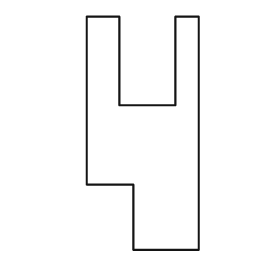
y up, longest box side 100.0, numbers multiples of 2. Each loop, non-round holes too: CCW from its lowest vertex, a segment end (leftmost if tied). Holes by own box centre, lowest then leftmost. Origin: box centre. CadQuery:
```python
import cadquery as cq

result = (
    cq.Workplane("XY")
    .moveTo(-4.0, -50.0)
    .lineTo(24.0, -50.0)
    .lineTo(24.0, 50.0)
    .lineTo(14.0, 50.0)
    .lineTo(14.0, 12.0)
    .lineTo(-10.0, 12.0)
    .lineTo(-10.0, 50.0)
    .lineTo(-24.0, 50.0)
    .lineTo(-24.0, -22.0)
    .lineTo(-4.0, -22.0)
    .close()
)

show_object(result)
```